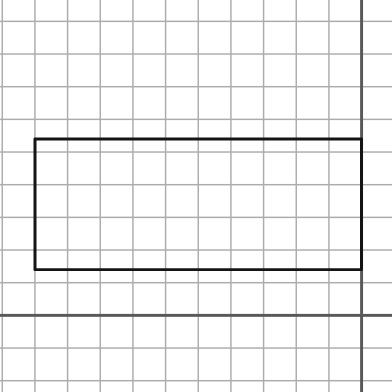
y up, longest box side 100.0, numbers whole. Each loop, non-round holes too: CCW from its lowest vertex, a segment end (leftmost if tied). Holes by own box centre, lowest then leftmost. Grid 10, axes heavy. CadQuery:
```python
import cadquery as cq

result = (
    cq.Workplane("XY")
    .moveTo(-100.0, 14.0)
    .lineTo(0.0, 14.0)
    .lineTo(0.0, 54.0)
    .lineTo(-100.0, 54.0)
    .close()
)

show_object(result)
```